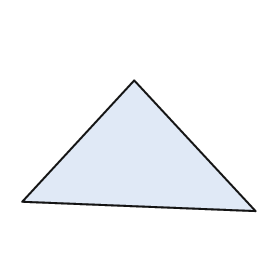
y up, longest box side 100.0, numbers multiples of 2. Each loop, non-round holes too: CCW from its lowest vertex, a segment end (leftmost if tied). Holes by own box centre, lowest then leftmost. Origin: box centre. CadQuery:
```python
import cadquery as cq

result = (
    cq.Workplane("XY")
    .moveTo(50.0, -28.0)
    .lineTo(-2.0, 28.0)
    .lineTo(-50.0, -24.0)
    .close()
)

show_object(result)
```